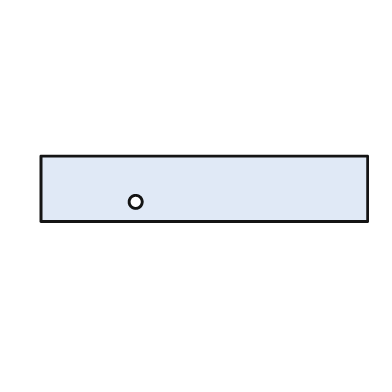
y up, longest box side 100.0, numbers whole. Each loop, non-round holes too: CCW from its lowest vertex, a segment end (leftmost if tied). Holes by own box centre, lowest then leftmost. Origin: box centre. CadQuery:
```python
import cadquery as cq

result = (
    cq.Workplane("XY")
    .moveTo(-50.0, -10.0)
    .lineTo(50.0, -10.0)
    .lineTo(50.0, 10.0)
    .lineTo(-50.0, 10.0)
    .close()
    .moveTo(-21.0, -4.0)
    .circle(2.0)
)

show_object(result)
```